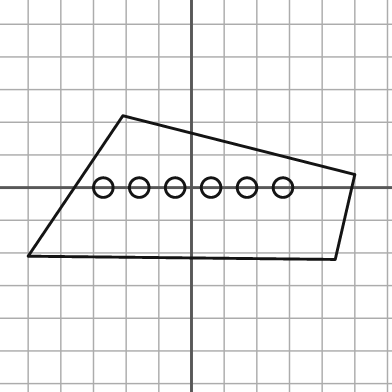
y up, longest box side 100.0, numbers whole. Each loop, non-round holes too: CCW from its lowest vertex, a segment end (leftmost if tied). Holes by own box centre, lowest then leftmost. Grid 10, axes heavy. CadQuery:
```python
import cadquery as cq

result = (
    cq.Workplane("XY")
    .moveTo(44.0, -22.0)
    .lineTo(50.0, 4.0)
    .lineTo(-21.0, 22.0)
    .lineTo(-50.0, -21.0)
    .close()
    .moveTo(-27.0, 0.0)
    .circle(3.0)
    .moveTo(-16.0, 0.0)
    .circle(3.0)
    .moveTo(-5.0, 0.0)
    .circle(3.0)
    .moveTo(6.0, 0.0)
    .circle(3.0)
    .moveTo(17.0, 0.0)
    .circle(3.0)
    .moveTo(28.0, 0.0)
    .circle(3.0)
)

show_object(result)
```